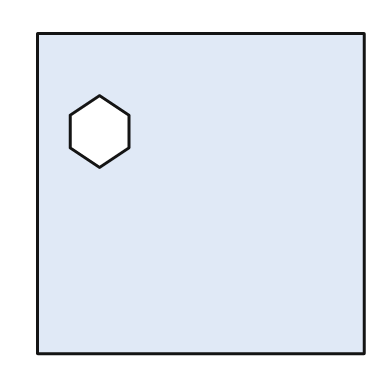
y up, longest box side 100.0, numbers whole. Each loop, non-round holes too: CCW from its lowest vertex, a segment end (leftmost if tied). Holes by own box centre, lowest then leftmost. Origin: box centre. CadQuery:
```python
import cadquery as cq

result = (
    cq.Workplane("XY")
    .moveTo(-50.0, -49.0)
    .lineTo(50.0, -49.0)
    .lineTo(50.0, 49.0)
    .lineTo(-50.0, 49.0)
    .close()
    .moveTo(-31.0, 8.0)
    .lineTo(-22.0, 14.0)
    .lineTo(-22.0, 24.0)
    .lineTo(-31.0, 30.0)
    .lineTo(-40.0, 24.0)
    .lineTo(-40.0, 14.0)
    .close()
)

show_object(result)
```